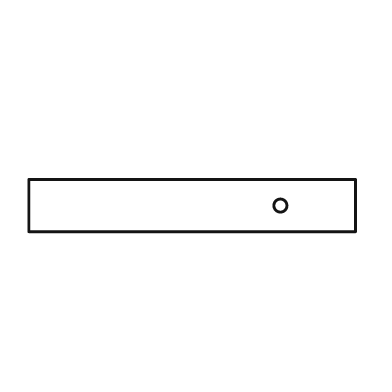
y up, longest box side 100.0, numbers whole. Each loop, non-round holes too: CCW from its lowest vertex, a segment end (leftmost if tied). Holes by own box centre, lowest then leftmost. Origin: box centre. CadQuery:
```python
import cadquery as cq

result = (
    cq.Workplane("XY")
    .moveTo(-50.0, -8.0)
    .lineTo(50.0, -8.0)
    .lineTo(50.0, 8.0)
    .lineTo(-50.0, 8.0)
    .close()
    .moveTo(27.0, 0.0)
    .circle(2.0)
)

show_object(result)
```